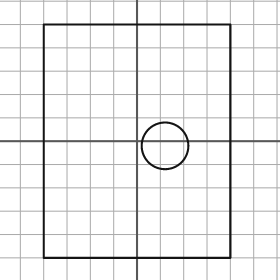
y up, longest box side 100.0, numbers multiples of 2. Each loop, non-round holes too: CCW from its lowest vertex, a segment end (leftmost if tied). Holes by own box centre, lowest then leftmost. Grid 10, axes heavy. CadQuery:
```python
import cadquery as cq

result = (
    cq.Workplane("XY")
    .moveTo(-40.0, -50.0)
    .lineTo(40.0, -50.0)
    .lineTo(40.0, 50.0)
    .lineTo(-40.0, 50.0)
    .close()
    .moveTo(12.0, -2.0)
    .circle(10.0)
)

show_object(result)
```